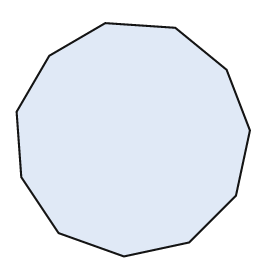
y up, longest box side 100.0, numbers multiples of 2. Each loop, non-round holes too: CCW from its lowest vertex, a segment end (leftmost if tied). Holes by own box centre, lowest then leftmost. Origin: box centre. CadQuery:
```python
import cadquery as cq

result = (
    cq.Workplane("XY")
    .moveTo(-4.0, -50.0)
    .lineTo(24.0, -44.0)
    .lineTo(44.0, -24.0)
    .lineTo(50.0, 4.0)
    .lineTo(40.0, 30.0)
    .lineTo(18.0, 48.0)
    .lineTo(-12.0, 50.0)
    .lineTo(-36.0, 36.0)
    .lineTo(-50.0, 12.0)
    .lineTo(-48.0, -16.0)
    .lineTo(-32.0, -40.0)
    .close()
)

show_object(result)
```